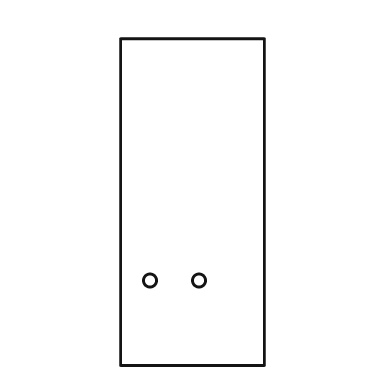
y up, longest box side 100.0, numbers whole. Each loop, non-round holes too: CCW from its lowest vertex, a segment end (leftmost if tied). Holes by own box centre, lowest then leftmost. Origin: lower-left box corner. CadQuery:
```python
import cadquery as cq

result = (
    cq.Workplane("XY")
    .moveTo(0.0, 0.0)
    .lineTo(44.0, 0.0)
    .lineTo(44.0, 100.0)
    .lineTo(0.0, 100.0)
    .close()
    .moveTo(9.0, 26.0)
    .circle(2.0)
    .moveTo(24.0, 26.0)
    .circle(2.0)
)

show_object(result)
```